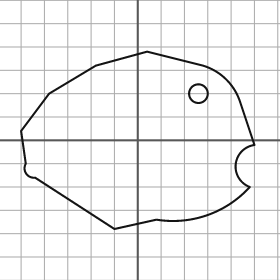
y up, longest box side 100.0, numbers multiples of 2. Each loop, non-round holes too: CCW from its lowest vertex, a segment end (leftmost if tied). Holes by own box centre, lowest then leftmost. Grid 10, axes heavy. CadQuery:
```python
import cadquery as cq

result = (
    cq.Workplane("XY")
    .moveTo(-10.0, -38.0)
    .lineTo(8.0, -34.0)
    .threePointArc((30.0, -32.0), (48.0, -20.0))
    .threePointArc((42.0, -10.0), (50.0, -2.0))
    .lineTo(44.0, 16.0)
    .threePointArc((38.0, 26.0), (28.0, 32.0))
    .lineTo(4.0, 38.0)
    .lineTo(-18.0, 32.0)
    .lineTo(-38.0, 20.0)
    .lineTo(-50.0, 4.0)
    .lineTo(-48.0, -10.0)
    .threePointArc((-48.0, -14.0), (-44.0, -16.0))
    .close()
    .moveTo(26.0, 20.0)
    .circle(4.0)
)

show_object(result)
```